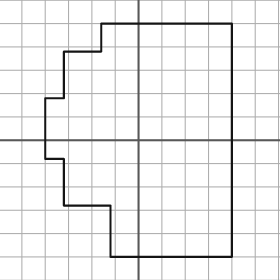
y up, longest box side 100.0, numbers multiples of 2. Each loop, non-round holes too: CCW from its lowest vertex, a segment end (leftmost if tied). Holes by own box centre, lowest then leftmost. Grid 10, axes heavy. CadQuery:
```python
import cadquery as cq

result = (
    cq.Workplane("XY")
    .moveTo(-12.0, -50.0)
    .lineTo(40.0, -50.0)
    .lineTo(40.0, 50.0)
    .lineTo(-16.0, 50.0)
    .lineTo(-16.0, 38.0)
    .lineTo(-32.0, 38.0)
    .lineTo(-32.0, 18.0)
    .lineTo(-40.0, 18.0)
    .lineTo(-40.0, -8.0)
    .lineTo(-32.0, -8.0)
    .lineTo(-32.0, -28.0)
    .lineTo(-12.0, -28.0)
    .close()
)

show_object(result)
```